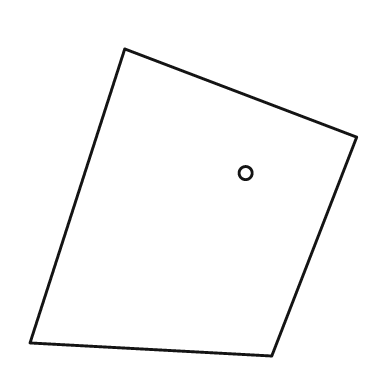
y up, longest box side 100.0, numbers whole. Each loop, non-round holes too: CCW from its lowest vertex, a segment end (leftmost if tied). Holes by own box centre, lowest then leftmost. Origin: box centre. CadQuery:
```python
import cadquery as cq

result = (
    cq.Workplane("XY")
    .moveTo(24.0, -47.0)
    .lineTo(50.0, 20.0)
    .lineTo(-21.0, 47.0)
    .lineTo(-50.0, -43.0)
    .close()
    .moveTo(16.0, 9.0)
    .circle(2.0)
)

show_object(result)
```